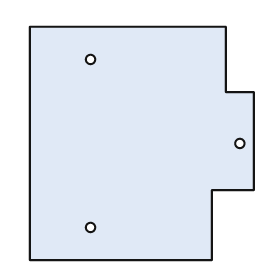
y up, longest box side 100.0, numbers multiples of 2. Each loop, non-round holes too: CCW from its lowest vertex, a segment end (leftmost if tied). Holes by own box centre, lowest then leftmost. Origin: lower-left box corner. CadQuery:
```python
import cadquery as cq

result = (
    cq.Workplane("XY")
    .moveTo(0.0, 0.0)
    .lineTo(78.0, 0.0)
    .lineTo(78.0, 30.0)
    .lineTo(96.0, 30.0)
    .lineTo(96.0, 72.0)
    .lineTo(84.0, 72.0)
    .lineTo(84.0, 100.0)
    .lineTo(0.0, 100.0)
    .close()
    .moveTo(26.0, 14.0)
    .circle(2.0)
    .moveTo(90.0, 50.0)
    .circle(2.0)
    .moveTo(26.0, 86.0)
    .circle(2.0)
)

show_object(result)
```